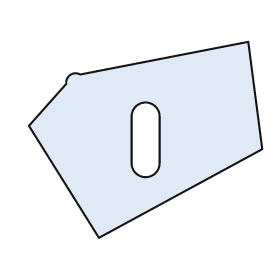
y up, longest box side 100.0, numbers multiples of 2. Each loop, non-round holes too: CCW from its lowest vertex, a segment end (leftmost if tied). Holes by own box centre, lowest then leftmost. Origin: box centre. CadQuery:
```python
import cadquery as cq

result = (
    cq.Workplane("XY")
    .moveTo(-20.0, -42.0)
    .lineTo(50.0, -4.0)
    .lineTo(44.0, 42.0)
    .lineTo(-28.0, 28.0)
    .threePointArc((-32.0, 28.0), (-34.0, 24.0))
    .lineTo(-50.0, 6.0)
    .close()
    .moveTo(-6.0, -10.0)
    .threePointArc((0.0, -16.0), (6.0, -10.0))
    .lineTo(6.0, 10.0)
    .threePointArc((0.0, 16.0), (-6.0, 10.0))
    .close()
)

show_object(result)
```